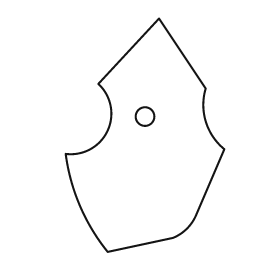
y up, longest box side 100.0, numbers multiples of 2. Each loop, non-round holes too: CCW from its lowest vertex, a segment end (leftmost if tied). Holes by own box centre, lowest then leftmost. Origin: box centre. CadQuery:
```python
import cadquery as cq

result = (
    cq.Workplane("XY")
    .moveTo(-16.0, -50.0)
    .lineTo(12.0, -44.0)
    .threePointArc((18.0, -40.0), (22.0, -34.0))
    .lineTo(34.0, -6.0)
    .threePointArc((26.0, 6.0), (26.0, 20.0))
    .lineTo(6.0, 50.0)
    .lineTo(-20.0, 22.0)
    .threePointArc((-16.0, 2.0), (-34.0, -8.0))
    .threePointArc((-28.0, -30.0), (-16.0, -50.0))
    .close()
    .moveTo(0.0, 8.0)
    .circle(4.0)
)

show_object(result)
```